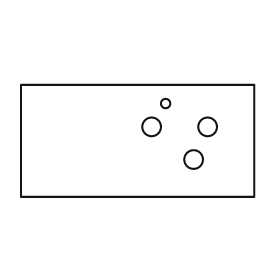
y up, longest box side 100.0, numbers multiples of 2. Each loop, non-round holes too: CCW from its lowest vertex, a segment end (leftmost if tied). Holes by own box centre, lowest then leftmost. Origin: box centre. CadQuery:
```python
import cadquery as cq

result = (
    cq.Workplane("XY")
    .moveTo(-50.0, -24.0)
    .lineTo(50.0, -24.0)
    .lineTo(50.0, 24.0)
    .lineTo(-50.0, 24.0)
    .close()
    .moveTo(24.0, -8.0)
    .circle(4.0)
    .moveTo(6.0, 6.0)
    .circle(4.0)
    .moveTo(30.0, 6.0)
    .circle(4.0)
    .moveTo(12.0, 16.0)
    .circle(2.0)
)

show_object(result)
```